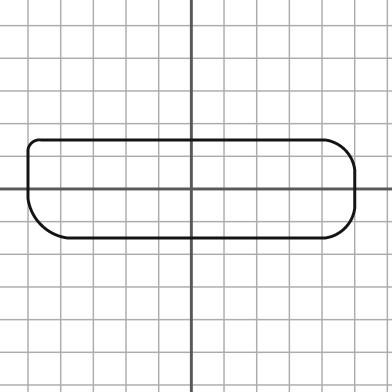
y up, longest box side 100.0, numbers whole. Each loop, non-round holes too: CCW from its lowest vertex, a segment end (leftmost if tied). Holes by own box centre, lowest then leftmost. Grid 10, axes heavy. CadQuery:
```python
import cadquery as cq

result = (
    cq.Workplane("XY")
    .moveTo(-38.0, -15.0)
    .lineTo(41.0, -15.0)
    .threePointArc((47.0, -12.0), (50.0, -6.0))
    .lineTo(50.0, 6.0)
    .threePointArc((47.0, 12.0), (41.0, 15.0))
    .lineTo(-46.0, 15.0)
    .threePointArc((-49.0, 14.0), (-50.0, 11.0))
    .lineTo(-50.0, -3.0)
    .threePointArc((-46.0, -11.0), (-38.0, -15.0))
    .close()
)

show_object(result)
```